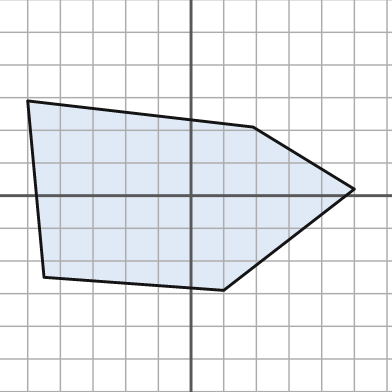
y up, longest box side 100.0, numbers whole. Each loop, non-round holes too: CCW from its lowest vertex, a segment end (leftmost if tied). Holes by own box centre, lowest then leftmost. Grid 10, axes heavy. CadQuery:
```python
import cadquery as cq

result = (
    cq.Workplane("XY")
    .moveTo(10.0, -29.0)
    .lineTo(50.0, 2.0)
    .lineTo(19.0, 21.0)
    .lineTo(-50.0, 29.0)
    .lineTo(-45.0, -25.0)
    .close()
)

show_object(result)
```